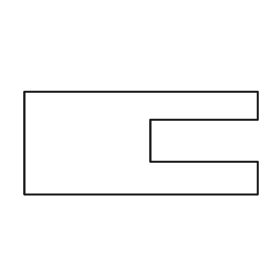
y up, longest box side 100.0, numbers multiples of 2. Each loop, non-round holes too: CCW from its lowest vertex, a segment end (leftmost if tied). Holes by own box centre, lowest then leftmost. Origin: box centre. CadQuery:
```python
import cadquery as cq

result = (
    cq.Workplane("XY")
    .moveTo(-50.0, -22.0)
    .lineTo(50.0, -22.0)
    .lineTo(50.0, -8.0)
    .lineTo(4.0, -8.0)
    .lineTo(4.0, 10.0)
    .lineTo(50.0, 10.0)
    .lineTo(50.0, 22.0)
    .lineTo(-50.0, 22.0)
    .close()
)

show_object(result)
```